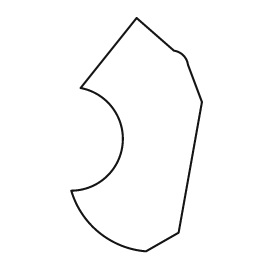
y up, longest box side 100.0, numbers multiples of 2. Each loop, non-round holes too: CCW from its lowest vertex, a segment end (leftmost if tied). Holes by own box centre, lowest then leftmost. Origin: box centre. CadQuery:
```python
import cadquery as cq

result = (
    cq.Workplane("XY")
    .moveTo(4.0, -50.0)
    .lineTo(18.0, -42.0)
    .lineTo(28.0, 14.0)
    .lineTo(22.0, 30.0)
    .threePointArc((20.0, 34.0), (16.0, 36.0))
    .lineTo(0.0, 50.0)
    .lineTo(-24.0, 20.0)
    .threePointArc((-6.0, -4.0), (-28.0, -24.0))
    .threePointArc((-16.0, -42.0), (4.0, -50.0))
    .close()
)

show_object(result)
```